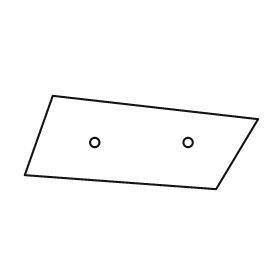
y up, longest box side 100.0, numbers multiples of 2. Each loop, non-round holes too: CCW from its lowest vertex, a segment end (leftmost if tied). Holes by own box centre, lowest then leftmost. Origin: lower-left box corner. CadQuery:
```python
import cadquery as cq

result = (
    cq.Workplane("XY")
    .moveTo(82.0, 0.0)
    .lineTo(100.0, 30.0)
    .lineTo(12.0, 40.0)
    .lineTo(0.0, 6.0)
    .close()
    .moveTo(30.0, 20.0)
    .circle(2.0)
    .moveTo(70.0, 20.0)
    .circle(2.0)
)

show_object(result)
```